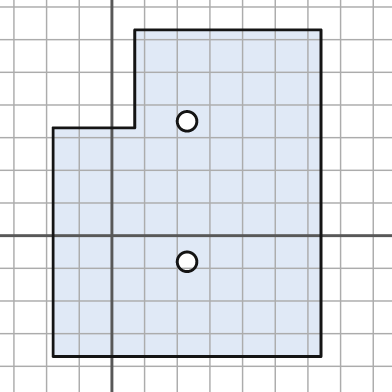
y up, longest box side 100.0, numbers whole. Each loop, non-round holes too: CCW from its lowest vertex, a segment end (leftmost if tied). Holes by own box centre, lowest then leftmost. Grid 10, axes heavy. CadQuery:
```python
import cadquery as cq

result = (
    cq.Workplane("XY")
    .moveTo(-18.0, -37.0)
    .lineTo(64.0, -37.0)
    .lineTo(64.0, 63.0)
    .lineTo(7.0, 63.0)
    .lineTo(7.0, 33.0)
    .lineTo(-18.0, 33.0)
    .close()
    .moveTo(23.0, -8.0)
    .circle(3.0)
    .moveTo(23.0, 35.0)
    .circle(3.0)
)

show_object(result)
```